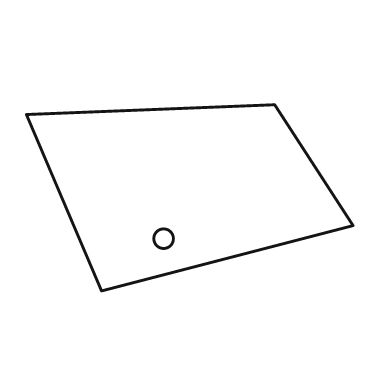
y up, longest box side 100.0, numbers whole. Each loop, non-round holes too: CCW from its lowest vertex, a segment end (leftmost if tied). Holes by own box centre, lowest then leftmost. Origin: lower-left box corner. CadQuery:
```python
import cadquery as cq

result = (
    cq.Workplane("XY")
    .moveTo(23.0, 0.0)
    .lineTo(100.0, 20.0)
    .lineTo(76.0, 57.0)
    .lineTo(0.0, 54.0)
    .close()
    .moveTo(42.0, 16.0)
    .circle(3.0)
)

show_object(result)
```